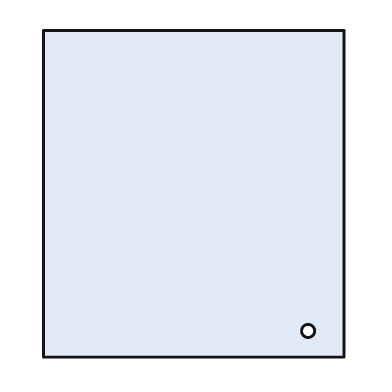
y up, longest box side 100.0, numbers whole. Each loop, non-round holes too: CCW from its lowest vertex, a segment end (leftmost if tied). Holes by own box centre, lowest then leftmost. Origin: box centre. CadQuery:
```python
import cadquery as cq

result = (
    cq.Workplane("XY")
    .moveTo(-46.0, -50.0)
    .lineTo(46.0, -50.0)
    .lineTo(46.0, 50.0)
    .lineTo(-46.0, 50.0)
    .close()
    .moveTo(35.0, -42.0)
    .circle(2.0)
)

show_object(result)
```